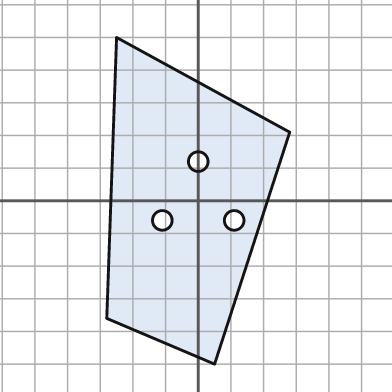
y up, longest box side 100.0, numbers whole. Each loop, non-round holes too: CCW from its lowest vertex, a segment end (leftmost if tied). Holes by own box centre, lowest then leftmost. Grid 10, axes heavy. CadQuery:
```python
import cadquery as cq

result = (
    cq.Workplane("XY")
    .moveTo(5.0, -50.0)
    .lineTo(28.0, 21.0)
    .lineTo(-25.0, 50.0)
    .lineTo(-28.0, -36.0)
    .close()
    .moveTo(-11.0, -6.0)
    .circle(3.0)
    .moveTo(11.0, -6.0)
    .circle(3.0)
    .moveTo(0.0, 12.0)
    .circle(3.0)
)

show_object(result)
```